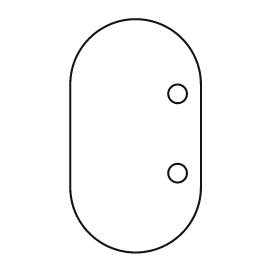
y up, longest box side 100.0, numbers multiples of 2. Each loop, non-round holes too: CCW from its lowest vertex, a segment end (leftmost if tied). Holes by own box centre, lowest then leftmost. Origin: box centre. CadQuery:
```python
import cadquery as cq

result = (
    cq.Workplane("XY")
    .moveTo(-28.0, -22.0)
    .threePointArc((0.0, -50.0), (28.0, -22.0))
    .lineTo(28.0, 22.0)
    .threePointArc((0.0, 50.0), (-28.0, 22.0))
    .close()
    .moveTo(18.0, -16.0)
    .circle(4.0)
    .moveTo(18.0, 18.0)
    .circle(4.0)
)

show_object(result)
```